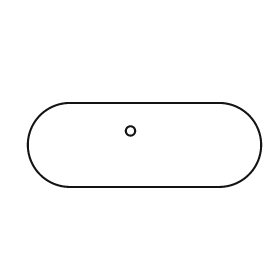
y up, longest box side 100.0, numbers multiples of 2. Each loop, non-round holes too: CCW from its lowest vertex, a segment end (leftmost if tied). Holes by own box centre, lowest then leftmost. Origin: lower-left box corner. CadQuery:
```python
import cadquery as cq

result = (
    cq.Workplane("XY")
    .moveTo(18.0, 0.0)
    .lineTo(82.0, 0.0)
    .threePointArc((100.0, 18.0), (82.0, 36.0))
    .lineTo(18.0, 36.0)
    .threePointArc((0.0, 18.0), (18.0, 0.0))
    .close()
    .moveTo(44.0, 24.0)
    .circle(2.0)
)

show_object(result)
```